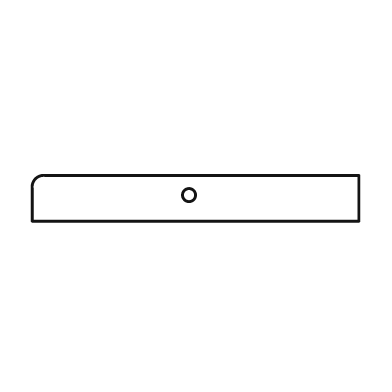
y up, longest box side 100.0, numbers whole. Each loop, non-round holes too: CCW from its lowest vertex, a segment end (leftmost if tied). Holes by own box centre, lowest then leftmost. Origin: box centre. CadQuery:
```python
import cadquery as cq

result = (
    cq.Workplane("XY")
    .moveTo(-50.0, -7.0)
    .lineTo(50.0, -7.0)
    .lineTo(50.0, 7.0)
    .lineTo(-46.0, 7.0)
    .threePointArc((-49.0, 6.0), (-50.0, 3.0))
    .close()
    .moveTo(-2.0, 1.0)
    .circle(2.0)
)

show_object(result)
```